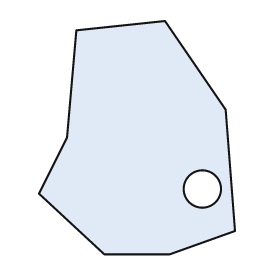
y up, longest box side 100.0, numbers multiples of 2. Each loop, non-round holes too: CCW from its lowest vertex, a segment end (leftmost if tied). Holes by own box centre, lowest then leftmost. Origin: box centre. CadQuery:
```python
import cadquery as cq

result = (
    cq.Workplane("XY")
    .moveTo(-14.0, -50.0)
    .lineTo(14.0, -50.0)
    .lineTo(42.0, -40.0)
    .lineTo(38.0, 12.0)
    .lineTo(12.0, 50.0)
    .lineTo(-26.0, 46.0)
    .lineTo(-30.0, 0.0)
    .lineTo(-42.0, -24.0)
    .close()
    .moveTo(28.0, -22.0)
    .circle(8.0)
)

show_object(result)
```